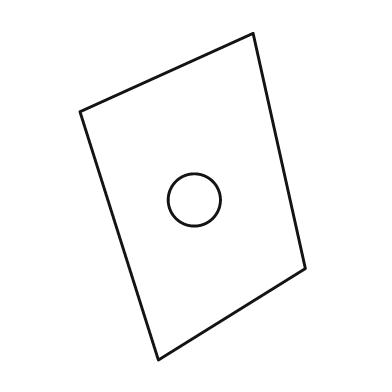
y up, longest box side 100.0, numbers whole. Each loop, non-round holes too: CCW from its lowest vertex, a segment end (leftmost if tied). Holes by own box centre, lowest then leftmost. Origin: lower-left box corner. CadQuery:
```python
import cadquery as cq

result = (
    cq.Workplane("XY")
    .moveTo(24.0, 0.0)
    .lineTo(69.0, 28.0)
    .lineTo(53.0, 100.0)
    .lineTo(0.0, 76.0)
    .close()
    .moveTo(35.0, 49.0)
    .circle(8.0)
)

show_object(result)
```